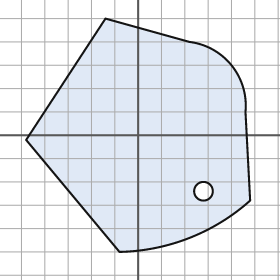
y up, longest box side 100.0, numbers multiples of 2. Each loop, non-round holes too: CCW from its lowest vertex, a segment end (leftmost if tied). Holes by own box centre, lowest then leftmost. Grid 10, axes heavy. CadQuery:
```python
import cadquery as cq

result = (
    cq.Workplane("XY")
    .moveTo(-8.0, -50.0)
    .threePointArc((22.0, -44.0), (48.0, -28.0))
    .lineTo(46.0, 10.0)
    .threePointArc((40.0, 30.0), (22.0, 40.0))
    .lineTo(-14.0, 50.0)
    .lineTo(-48.0, -2.0)
    .close()
    .moveTo(28.0, -24.0)
    .circle(4.0)
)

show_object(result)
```